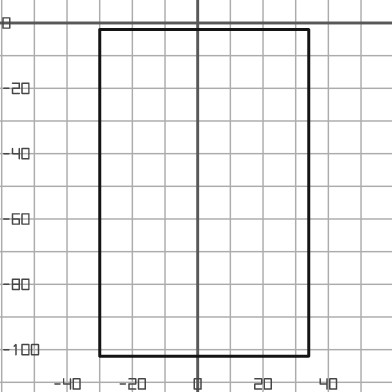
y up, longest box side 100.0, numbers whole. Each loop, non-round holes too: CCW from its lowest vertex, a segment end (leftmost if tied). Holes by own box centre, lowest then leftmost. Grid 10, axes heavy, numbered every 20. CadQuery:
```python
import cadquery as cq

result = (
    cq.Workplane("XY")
    .moveTo(-30.0, -102.0)
    .lineTo(34.0, -102.0)
    .lineTo(34.0, -2.0)
    .lineTo(-30.0, -2.0)
    .close()
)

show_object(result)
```